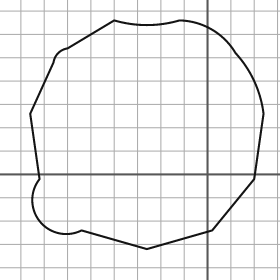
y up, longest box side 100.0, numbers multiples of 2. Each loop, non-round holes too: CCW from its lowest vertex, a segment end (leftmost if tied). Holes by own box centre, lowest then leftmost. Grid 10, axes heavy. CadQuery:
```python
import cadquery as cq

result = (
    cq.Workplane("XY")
    .moveTo(-26.0, -32.0)
    .lineTo(2.0, -24.0)
    .lineTo(20.0, -2.0)
    .lineTo(24.0, 26.0)
    .threePointArc((20.0, 40.0), (12.0, 52.0))
    .threePointArc((2.0, 62.0), (-12.0, 66.0))
    .threePointArc((-26.0, 64.0), (-40.0, 66.0))
    .lineTo(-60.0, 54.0)
    .threePointArc((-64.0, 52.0), (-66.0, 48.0))
    .lineTo(-76.0, 26.0)
    .lineTo(-72.0, -2.0)
    .threePointArc((-72.0, -20.0), (-54.0, -24.0))
    .close()
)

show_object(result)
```